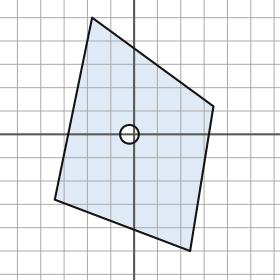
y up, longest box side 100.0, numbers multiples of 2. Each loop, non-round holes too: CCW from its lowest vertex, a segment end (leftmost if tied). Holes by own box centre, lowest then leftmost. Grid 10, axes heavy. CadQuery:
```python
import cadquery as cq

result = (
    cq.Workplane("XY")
    .moveTo(24.0, -50.0)
    .lineTo(34.0, 12.0)
    .lineTo(-18.0, 50.0)
    .lineTo(-34.0, -28.0)
    .close()
    .moveTo(-2.0, 0.0)
    .circle(4.0)
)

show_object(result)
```